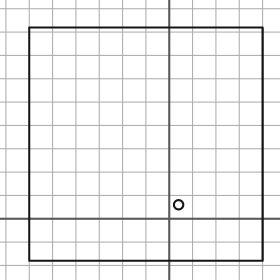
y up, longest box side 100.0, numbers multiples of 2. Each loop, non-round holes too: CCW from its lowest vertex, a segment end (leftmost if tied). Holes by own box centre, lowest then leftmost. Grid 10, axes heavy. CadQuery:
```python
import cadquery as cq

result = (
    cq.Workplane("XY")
    .moveTo(-60.0, -18.0)
    .lineTo(40.0, -18.0)
    .lineTo(40.0, 82.0)
    .lineTo(-60.0, 82.0)
    .close()
    .moveTo(4.0, 6.0)
    .circle(2.0)
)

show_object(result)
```